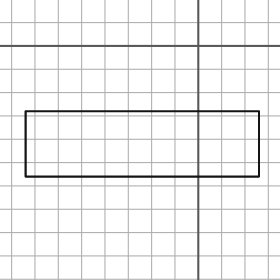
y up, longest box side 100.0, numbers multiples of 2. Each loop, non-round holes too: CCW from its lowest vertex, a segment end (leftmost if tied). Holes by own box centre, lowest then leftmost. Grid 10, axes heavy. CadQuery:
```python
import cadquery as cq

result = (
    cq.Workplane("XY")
    .moveTo(-74.0, -56.0)
    .lineTo(26.0, -56.0)
    .lineTo(26.0, -28.0)
    .lineTo(-74.0, -28.0)
    .close()
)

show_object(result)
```